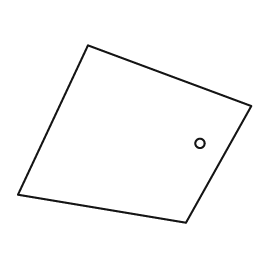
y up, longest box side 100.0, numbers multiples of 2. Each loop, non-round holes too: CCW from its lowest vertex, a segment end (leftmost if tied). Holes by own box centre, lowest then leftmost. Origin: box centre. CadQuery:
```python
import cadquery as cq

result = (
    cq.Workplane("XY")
    .moveTo(22.0, -38.0)
    .lineTo(50.0, 12.0)
    .lineTo(-20.0, 38.0)
    .lineTo(-50.0, -26.0)
    .close()
    .moveTo(28.0, -4.0)
    .circle(2.0)
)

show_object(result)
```